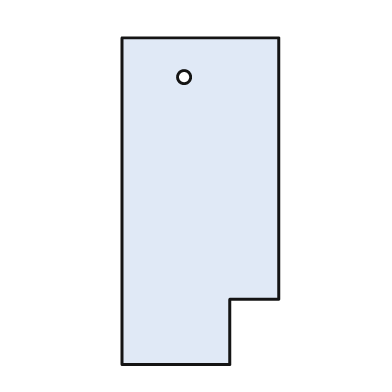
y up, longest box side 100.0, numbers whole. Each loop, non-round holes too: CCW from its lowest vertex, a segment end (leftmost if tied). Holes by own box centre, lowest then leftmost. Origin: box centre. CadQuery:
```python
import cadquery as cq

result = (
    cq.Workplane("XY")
    .moveTo(-24.0, -50.0)
    .lineTo(9.0, -50.0)
    .lineTo(9.0, -30.0)
    .lineTo(24.0, -30.0)
    .lineTo(24.0, 50.0)
    .lineTo(-24.0, 50.0)
    .close()
    .moveTo(-5.0, 38.0)
    .circle(2.0)
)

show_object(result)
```